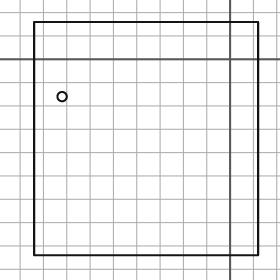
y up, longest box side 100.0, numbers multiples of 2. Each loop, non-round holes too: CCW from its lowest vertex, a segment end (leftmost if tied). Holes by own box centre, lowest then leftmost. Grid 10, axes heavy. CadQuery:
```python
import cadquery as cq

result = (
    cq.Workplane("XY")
    .moveTo(-84.0, -84.0)
    .lineTo(12.0, -84.0)
    .lineTo(12.0, 16.0)
    .lineTo(-84.0, 16.0)
    .close()
    .moveTo(-72.0, -16.0)
    .circle(2.0)
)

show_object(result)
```